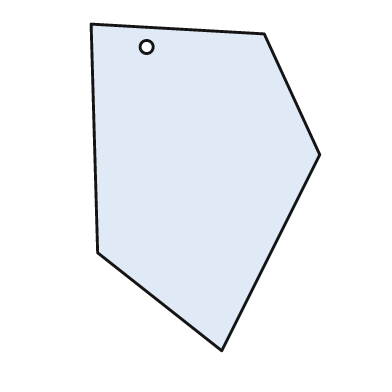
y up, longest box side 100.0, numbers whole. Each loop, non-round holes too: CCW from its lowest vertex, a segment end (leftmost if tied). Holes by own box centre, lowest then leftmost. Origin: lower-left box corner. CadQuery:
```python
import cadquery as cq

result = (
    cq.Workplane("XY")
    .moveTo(40.0, 0.0)
    .lineTo(70.0, 60.0)
    .lineTo(53.0, 97.0)
    .lineTo(0.0, 100.0)
    .lineTo(2.0, 30.0)
    .close()
    .moveTo(17.0, 93.0)
    .circle(2.0)
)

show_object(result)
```